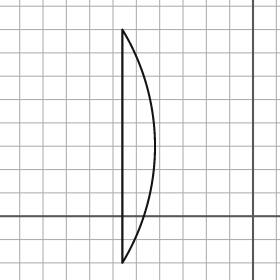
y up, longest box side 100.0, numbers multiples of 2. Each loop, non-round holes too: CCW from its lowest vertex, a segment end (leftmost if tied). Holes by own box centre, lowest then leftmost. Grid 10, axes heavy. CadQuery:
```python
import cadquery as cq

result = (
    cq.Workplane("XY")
    .moveTo(-56.0, -20.0)
    .threePointArc((-42.0, 30.0), (-56.0, 80.0))
    .close()
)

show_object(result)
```